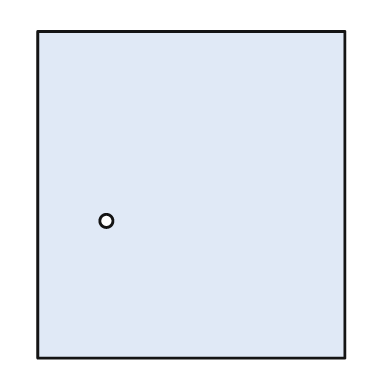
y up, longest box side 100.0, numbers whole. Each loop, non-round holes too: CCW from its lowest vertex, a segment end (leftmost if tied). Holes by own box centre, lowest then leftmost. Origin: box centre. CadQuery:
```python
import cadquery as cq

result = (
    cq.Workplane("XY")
    .moveTo(-47.0, -50.0)
    .lineTo(47.0, -50.0)
    .lineTo(47.0, 50.0)
    .lineTo(-47.0, 50.0)
    .close()
    .moveTo(-26.0, -8.0)
    .circle(2.0)
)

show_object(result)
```